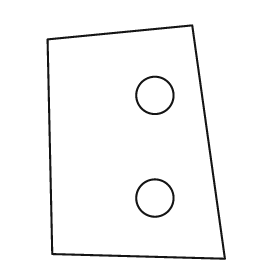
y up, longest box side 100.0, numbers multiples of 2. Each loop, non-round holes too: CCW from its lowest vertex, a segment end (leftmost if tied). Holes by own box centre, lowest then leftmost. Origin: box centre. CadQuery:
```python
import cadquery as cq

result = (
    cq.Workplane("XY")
    .moveTo(38.0, -50.0)
    .lineTo(24.0, 50.0)
    .lineTo(-38.0, 44.0)
    .lineTo(-36.0, -48.0)
    .close()
    .moveTo(8.0, -24.0)
    .circle(8.0)
    .moveTo(8.0, 20.0)
    .circle(8.0)
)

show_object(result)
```